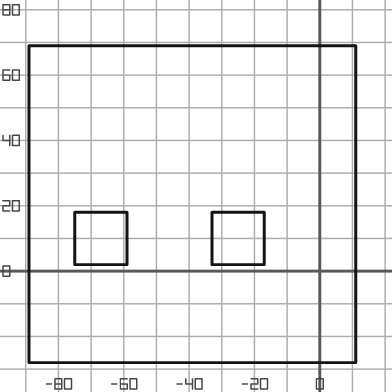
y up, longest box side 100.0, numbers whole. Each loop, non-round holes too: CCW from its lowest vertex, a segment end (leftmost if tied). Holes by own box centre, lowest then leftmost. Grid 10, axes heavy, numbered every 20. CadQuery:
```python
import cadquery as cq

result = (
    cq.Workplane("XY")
    .moveTo(-89.0, -28.0)
    .lineTo(11.0, -28.0)
    .lineTo(11.0, 69.0)
    .lineTo(-89.0, 69.0)
    .close()
    .moveTo(-75.0, 2.0)
    .lineTo(-59.0, 2.0)
    .lineTo(-59.0, 18.0)
    .lineTo(-75.0, 18.0)
    .close()
    .moveTo(-33.0, 2.0)
    .lineTo(-17.0, 2.0)
    .lineTo(-17.0, 18.0)
    .lineTo(-33.0, 18.0)
    .close()
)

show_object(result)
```